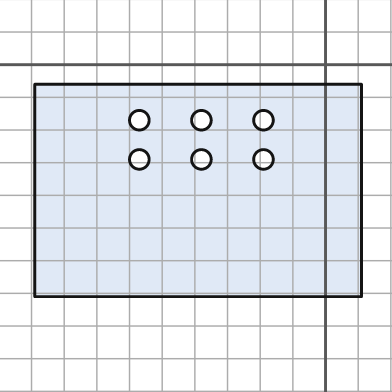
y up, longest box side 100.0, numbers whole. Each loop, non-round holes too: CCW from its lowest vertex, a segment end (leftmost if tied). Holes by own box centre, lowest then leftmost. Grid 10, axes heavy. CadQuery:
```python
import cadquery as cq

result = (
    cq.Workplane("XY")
    .moveTo(-89.0, -71.0)
    .lineTo(11.0, -71.0)
    .lineTo(11.0, -6.0)
    .lineTo(-89.0, -6.0)
    .close()
    .moveTo(-57.0, -29.0)
    .circle(3.0)
    .moveTo(-38.0, -29.0)
    .circle(3.0)
    .moveTo(-19.0, -29.0)
    .circle(3.0)
    .moveTo(-57.0, -17.0)
    .circle(3.0)
    .moveTo(-38.0, -17.0)
    .circle(3.0)
    .moveTo(-19.0, -17.0)
    .circle(3.0)
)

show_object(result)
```